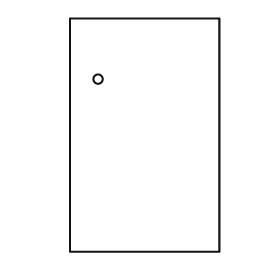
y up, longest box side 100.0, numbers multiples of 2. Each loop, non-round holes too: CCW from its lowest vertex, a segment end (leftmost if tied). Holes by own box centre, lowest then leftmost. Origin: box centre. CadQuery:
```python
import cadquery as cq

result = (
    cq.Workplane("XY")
    .moveTo(-32.0, -50.0)
    .lineTo(32.0, -50.0)
    .lineTo(32.0, 50.0)
    .lineTo(-32.0, 50.0)
    .close()
    .moveTo(-20.0, 24.0)
    .circle(2.0)
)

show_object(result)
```